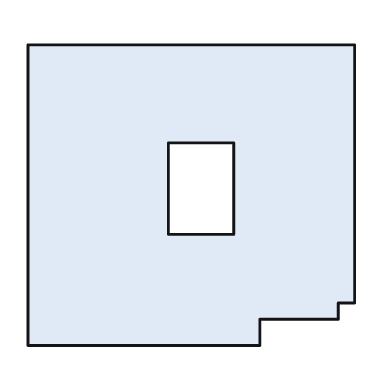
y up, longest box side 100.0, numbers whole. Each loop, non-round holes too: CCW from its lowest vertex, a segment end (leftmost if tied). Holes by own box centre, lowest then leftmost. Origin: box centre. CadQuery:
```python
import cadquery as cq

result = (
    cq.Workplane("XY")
    .moveTo(-50.0, -46.0)
    .lineTo(21.0, -46.0)
    .lineTo(21.0, -38.0)
    .lineTo(45.0, -38.0)
    .lineTo(45.0, -33.0)
    .lineTo(50.0, -33.0)
    .lineTo(50.0, 46.0)
    .lineTo(-50.0, 46.0)
    .close()
    .moveTo(-7.0, -12.0)
    .lineTo(13.0, -12.0)
    .lineTo(13.0, 16.0)
    .lineTo(-7.0, 16.0)
    .close()
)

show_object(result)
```